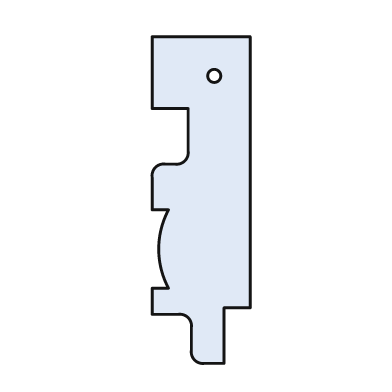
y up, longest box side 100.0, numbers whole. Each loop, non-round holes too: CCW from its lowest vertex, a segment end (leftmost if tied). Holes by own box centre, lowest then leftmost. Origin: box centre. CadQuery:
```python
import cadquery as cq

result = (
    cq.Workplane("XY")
    .moveTo(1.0, -50.0)
    .lineTo(7.0, -50.0)
    .lineTo(7.0, -33.0)
    .lineTo(15.0, -33.0)
    .lineTo(15.0, 50.0)
    .lineTo(-15.0, 50.0)
    .lineTo(-15.0, 28.0)
    .lineTo(-4.0, 28.0)
    .lineTo(-4.0, 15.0)
    .threePointArc((-5.0, 12.0), (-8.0, 11.0))
    .lineTo(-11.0, 11.0)
    .threePointArc((-14.0, 10.0), (-15.0, 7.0))
    .lineTo(-15.0, -3.0)
    .lineTo(-10.0, -3.0)
    .threePointArc((-13.0, -15.0), (-10.0, -27.0))
    .lineTo(-15.0, -27.0)
    .lineTo(-15.0, -35.0)
    .lineTo(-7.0, -35.0)
    .threePointArc((-4.0, -36.0), (-3.0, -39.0))
    .lineTo(-3.0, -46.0)
    .threePointArc((-2.0, -49.0), (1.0, -50.0))
    .close()
    .moveTo(4.0, 38.0)
    .circle(2.0)
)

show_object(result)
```